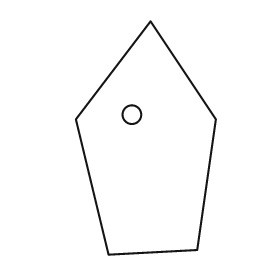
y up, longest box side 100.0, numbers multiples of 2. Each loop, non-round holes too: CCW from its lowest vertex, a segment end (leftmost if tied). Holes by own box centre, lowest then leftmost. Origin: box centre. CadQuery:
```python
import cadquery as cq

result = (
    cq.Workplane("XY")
    .moveTo(-16.0, -50.0)
    .lineTo(22.0, -48.0)
    .lineTo(30.0, 8.0)
    .lineTo(2.0, 50.0)
    .lineTo(-30.0, 8.0)
    .close()
    .moveTo(-6.0, 10.0)
    .circle(4.0)
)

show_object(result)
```